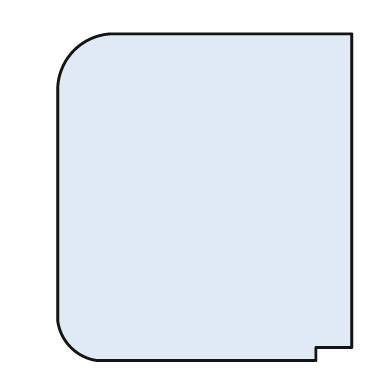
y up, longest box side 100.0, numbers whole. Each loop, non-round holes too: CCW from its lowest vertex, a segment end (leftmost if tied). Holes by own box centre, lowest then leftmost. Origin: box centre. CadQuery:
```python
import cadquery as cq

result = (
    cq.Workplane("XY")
    .moveTo(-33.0, -50.0)
    .lineTo(34.0, -50.0)
    .lineTo(34.0, -46.0)
    .lineTo(45.0, -46.0)
    .lineTo(45.0, 50.0)
    .lineTo(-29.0, 50.0)
    .threePointArc((-40.0, 45.0), (-45.0, 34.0))
    .lineTo(-45.0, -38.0)
    .threePointArc((-41.0, -46.0), (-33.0, -50.0))
    .close()
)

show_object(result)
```